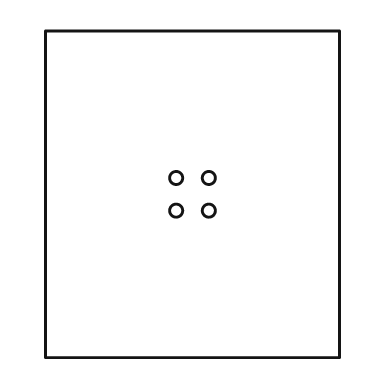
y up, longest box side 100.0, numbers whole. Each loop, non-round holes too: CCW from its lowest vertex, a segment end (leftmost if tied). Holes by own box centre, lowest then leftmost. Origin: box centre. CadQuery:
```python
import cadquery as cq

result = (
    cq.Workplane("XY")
    .moveTo(-45.0, -50.0)
    .lineTo(45.0, -50.0)
    .lineTo(45.0, 50.0)
    .lineTo(-45.0, 50.0)
    .close()
    .moveTo(-5.0, -5.0)
    .circle(2.0)
    .moveTo(5.0, -5.0)
    .circle(2.0)
    .moveTo(-5.0, 5.0)
    .circle(2.0)
    .moveTo(5.0, 5.0)
    .circle(2.0)
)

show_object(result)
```